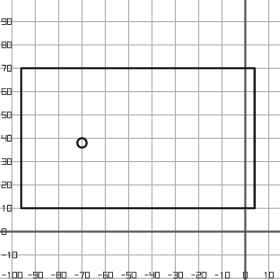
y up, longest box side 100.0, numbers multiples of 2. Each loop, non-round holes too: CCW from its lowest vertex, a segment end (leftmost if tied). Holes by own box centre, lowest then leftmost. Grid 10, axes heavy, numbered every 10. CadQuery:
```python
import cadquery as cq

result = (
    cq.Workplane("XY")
    .moveTo(-96.0, 10.0)
    .lineTo(4.0, 10.0)
    .lineTo(4.0, 70.0)
    .lineTo(-96.0, 70.0)
    .close()
    .moveTo(-70.0, 38.0)
    .circle(2.0)
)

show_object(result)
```